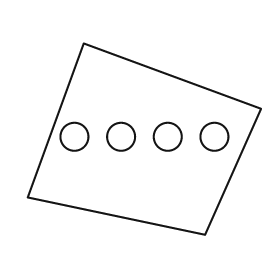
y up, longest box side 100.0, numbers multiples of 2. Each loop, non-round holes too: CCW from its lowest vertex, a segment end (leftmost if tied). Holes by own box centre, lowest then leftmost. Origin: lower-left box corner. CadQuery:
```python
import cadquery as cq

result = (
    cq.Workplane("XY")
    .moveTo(76.0, 0.0)
    .lineTo(100.0, 54.0)
    .lineTo(24.0, 82.0)
    .lineTo(0.0, 16.0)
    .close()
    .moveTo(20.0, 42.0)
    .circle(6.0)
    .moveTo(40.0, 42.0)
    .circle(6.0)
    .moveTo(60.0, 42.0)
    .circle(6.0)
    .moveTo(80.0, 42.0)
    .circle(6.0)
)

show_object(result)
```